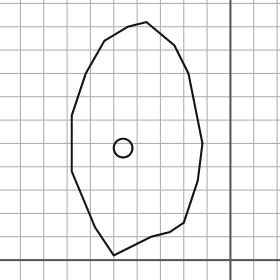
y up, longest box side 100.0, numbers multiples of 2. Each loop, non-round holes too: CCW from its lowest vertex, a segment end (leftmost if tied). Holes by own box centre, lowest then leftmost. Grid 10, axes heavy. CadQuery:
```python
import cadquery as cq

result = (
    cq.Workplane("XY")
    .moveTo(-50.0, 2.0)
    .lineTo(-34.0, 10.0)
    .lineTo(-26.0, 12.0)
    .lineTo(-20.0, 16.0)
    .lineTo(-14.0, 34.0)
    .lineTo(-12.0, 50.0)
    .lineTo(-18.0, 80.0)
    .lineTo(-24.0, 92.0)
    .lineTo(-36.0, 102.0)
    .lineTo(-44.0, 100.0)
    .lineTo(-54.0, 94.0)
    .lineTo(-62.0, 80.0)
    .lineTo(-68.0, 62.0)
    .lineTo(-68.0, 38.0)
    .lineTo(-58.0, 14.0)
    .close()
    .moveTo(-46.0, 48.0)
    .circle(4.0)
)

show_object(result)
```